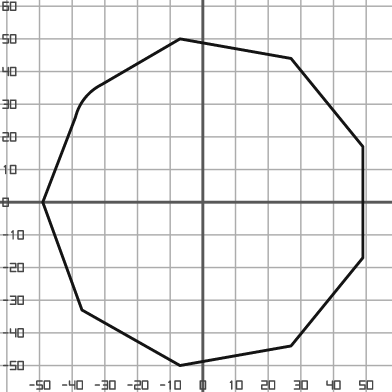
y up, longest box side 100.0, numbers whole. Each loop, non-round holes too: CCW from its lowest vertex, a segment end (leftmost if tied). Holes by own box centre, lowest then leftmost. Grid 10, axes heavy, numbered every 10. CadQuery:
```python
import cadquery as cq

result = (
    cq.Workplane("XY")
    .moveTo(-7.0, -50.0)
    .lineTo(27.0, -44.0)
    .lineTo(49.0, -17.0)
    .lineTo(49.0, 17.0)
    .lineTo(27.0, 44.0)
    .lineTo(-7.0, 50.0)
    .lineTo(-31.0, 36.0)
    .threePointArc((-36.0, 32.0), (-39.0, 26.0))
    .lineTo(-49.0, 0.0)
    .lineTo(-37.0, -33.0)
    .close()
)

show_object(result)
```